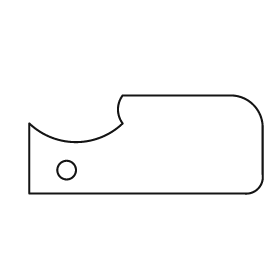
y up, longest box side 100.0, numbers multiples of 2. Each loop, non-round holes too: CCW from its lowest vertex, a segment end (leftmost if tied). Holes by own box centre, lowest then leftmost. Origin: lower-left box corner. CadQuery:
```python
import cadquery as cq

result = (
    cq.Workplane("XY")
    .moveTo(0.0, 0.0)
    .lineTo(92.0, 0.0)
    .threePointArc((98.0, 2.0), (100.0, 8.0))
    .lineTo(100.0, 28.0)
    .threePointArc((96.0, 38.0), (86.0, 42.0))
    .lineTo(40.0, 42.0)
    .threePointArc((38.0, 36.0), (40.0, 30.0))
    .threePointArc((20.0, 22.0), (0.0, 30.0))
    .close()
    .moveTo(16.0, 10.0)
    .circle(4.0)
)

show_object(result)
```